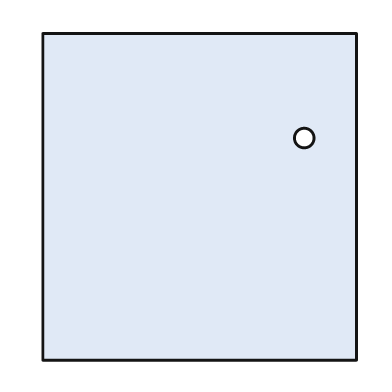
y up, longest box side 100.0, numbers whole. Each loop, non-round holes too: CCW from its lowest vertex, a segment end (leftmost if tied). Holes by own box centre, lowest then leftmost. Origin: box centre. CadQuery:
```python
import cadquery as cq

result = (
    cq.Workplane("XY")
    .moveTo(-48.0, -50.0)
    .lineTo(48.0, -50.0)
    .lineTo(48.0, 50.0)
    .lineTo(-48.0, 50.0)
    .close()
    .moveTo(32.0, 18.0)
    .circle(3.0)
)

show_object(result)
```